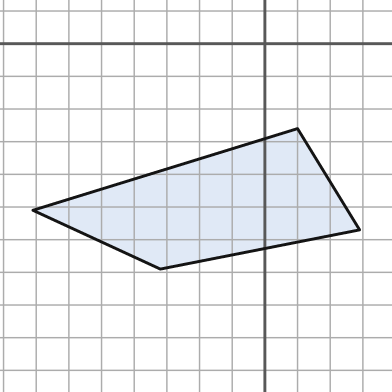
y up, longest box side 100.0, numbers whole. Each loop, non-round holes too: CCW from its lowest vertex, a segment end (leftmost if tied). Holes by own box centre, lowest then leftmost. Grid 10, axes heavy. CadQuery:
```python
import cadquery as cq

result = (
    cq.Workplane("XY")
    .moveTo(-32.0, -69.0)
    .lineTo(29.0, -57.0)
    .lineTo(10.0, -26.0)
    .lineTo(-71.0, -51.0)
    .close()
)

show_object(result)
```